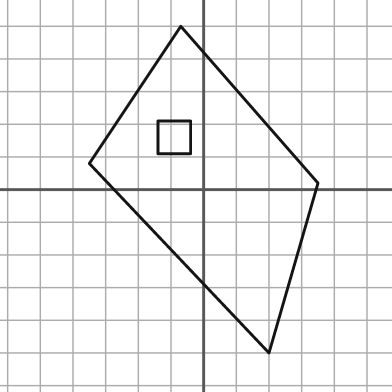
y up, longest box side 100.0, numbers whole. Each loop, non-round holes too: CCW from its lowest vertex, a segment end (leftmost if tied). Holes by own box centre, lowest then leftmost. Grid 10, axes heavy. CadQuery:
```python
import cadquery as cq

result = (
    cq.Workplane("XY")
    .moveTo(20.0, -50.0)
    .lineTo(35.0, 2.0)
    .lineTo(-7.0, 50.0)
    .lineTo(-35.0, 8.0)
    .close()
    .moveTo(-14.0, 11.0)
    .lineTo(-4.0, 11.0)
    .lineTo(-4.0, 21.0)
    .lineTo(-14.0, 21.0)
    .close()
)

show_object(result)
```